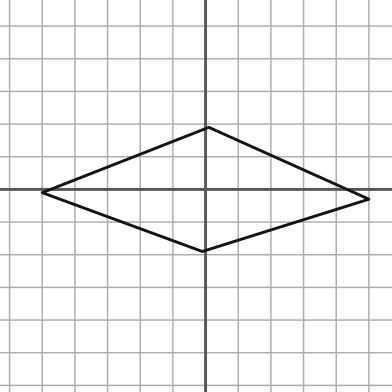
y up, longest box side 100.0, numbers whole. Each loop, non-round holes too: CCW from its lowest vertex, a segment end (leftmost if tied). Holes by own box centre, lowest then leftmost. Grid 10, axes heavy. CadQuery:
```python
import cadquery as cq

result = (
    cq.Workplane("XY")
    .moveTo(-1.0, -19.0)
    .lineTo(50.0, -3.0)
    .lineTo(1.0, 19.0)
    .lineTo(-50.0, -1.0)
    .close()
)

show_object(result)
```